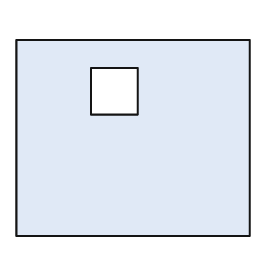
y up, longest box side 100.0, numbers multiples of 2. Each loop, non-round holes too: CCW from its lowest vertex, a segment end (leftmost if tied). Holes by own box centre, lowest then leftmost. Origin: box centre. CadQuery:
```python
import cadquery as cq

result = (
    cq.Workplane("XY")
    .moveTo(-50.0, -42.0)
    .lineTo(50.0, -42.0)
    .lineTo(50.0, 42.0)
    .lineTo(-50.0, 42.0)
    .close()
    .moveTo(-18.0, 10.0)
    .lineTo(2.0, 10.0)
    .lineTo(2.0, 30.0)
    .lineTo(-18.0, 30.0)
    .close()
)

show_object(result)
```